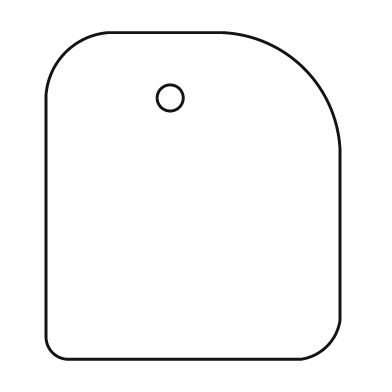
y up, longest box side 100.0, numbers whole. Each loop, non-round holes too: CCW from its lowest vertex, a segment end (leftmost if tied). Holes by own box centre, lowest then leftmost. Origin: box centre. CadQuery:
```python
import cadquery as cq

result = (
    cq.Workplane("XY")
    .moveTo(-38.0, -50.0)
    .lineTo(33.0, -50.0)
    .threePointArc((41.0, -46.0), (45.0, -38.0))
    .lineTo(45.0, 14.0)
    .threePointArc((34.0, 39.0), (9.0, 50.0))
    .lineTo(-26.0, 50.0)
    .threePointArc((-39.0, 44.0), (-45.0, 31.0))
    .lineTo(-45.0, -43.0)
    .threePointArc((-43.0, -48.0), (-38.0, -50.0))
    .close()
    .moveTo(-7.0, 30.0)
    .circle(4.0)
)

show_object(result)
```